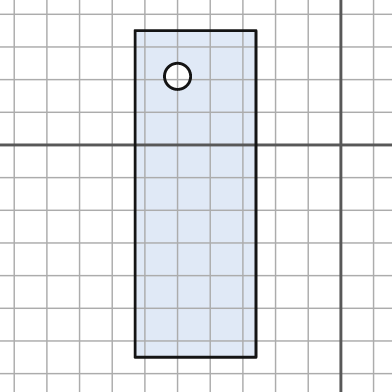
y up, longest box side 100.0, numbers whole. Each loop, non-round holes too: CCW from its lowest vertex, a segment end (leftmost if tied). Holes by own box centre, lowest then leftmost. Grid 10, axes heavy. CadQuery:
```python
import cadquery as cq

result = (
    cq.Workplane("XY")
    .moveTo(-63.0, -65.0)
    .lineTo(-26.0, -65.0)
    .lineTo(-26.0, 35.0)
    .lineTo(-63.0, 35.0)
    .close()
    .moveTo(-50.0, 21.0)
    .circle(4.0)
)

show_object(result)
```